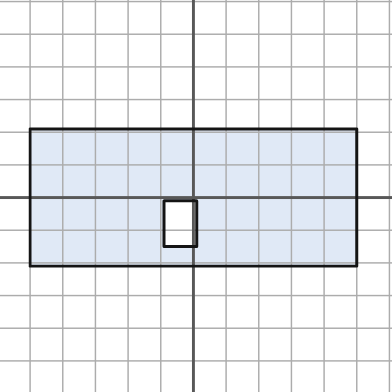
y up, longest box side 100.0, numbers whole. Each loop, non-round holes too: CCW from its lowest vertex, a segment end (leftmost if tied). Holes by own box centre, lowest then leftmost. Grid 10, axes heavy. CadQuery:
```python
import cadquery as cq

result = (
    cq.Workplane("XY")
    .moveTo(-50.0, -21.0)
    .lineTo(50.0, -21.0)
    .lineTo(50.0, 21.0)
    .lineTo(-50.0, 21.0)
    .close()
    .moveTo(-9.0, -15.0)
    .lineTo(1.0, -15.0)
    .lineTo(1.0, -1.0)
    .lineTo(-9.0, -1.0)
    .close()
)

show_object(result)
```